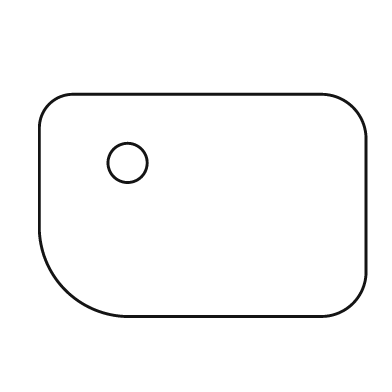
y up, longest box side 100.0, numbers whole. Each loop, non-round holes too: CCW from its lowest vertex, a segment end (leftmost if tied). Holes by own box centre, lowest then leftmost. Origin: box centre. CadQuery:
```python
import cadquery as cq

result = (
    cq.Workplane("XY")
    .moveTo(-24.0, -34.0)
    .lineTo(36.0, -34.0)
    .threePointArc((46.0, -30.0), (50.0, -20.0))
    .lineTo(50.0, 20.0)
    .threePointArc((46.0, 30.0), (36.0, 34.0))
    .lineTo(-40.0, 34.0)
    .threePointArc((-47.0, 31.0), (-50.0, 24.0))
    .lineTo(-50.0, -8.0)
    .threePointArc((-42.0, -26.0), (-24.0, -34.0))
    .close()
    .moveTo(-23.0, 13.0)
    .circle(6.0)
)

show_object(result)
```